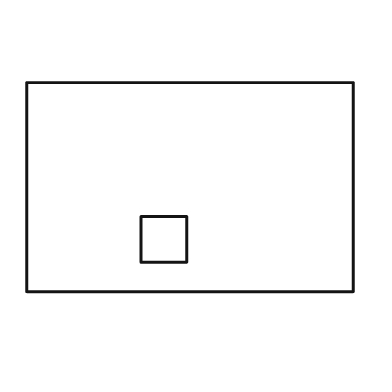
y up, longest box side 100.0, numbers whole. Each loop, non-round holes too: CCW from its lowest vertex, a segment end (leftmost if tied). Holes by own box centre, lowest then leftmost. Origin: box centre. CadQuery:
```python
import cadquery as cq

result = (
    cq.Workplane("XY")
    .moveTo(-50.0, -32.0)
    .lineTo(50.0, -32.0)
    .lineTo(50.0, 32.0)
    .lineTo(-50.0, 32.0)
    .close()
    .moveTo(-15.0, -23.0)
    .lineTo(-1.0, -23.0)
    .lineTo(-1.0, -9.0)
    .lineTo(-15.0, -9.0)
    .close()
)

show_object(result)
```